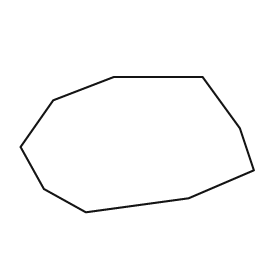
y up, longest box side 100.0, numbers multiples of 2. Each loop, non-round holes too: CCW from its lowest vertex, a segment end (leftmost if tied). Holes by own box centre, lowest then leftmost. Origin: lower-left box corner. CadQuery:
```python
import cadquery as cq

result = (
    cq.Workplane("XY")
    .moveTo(28.0, 0.0)
    .lineTo(72.0, 6.0)
    .lineTo(100.0, 18.0)
    .lineTo(94.0, 36.0)
    .lineTo(78.0, 58.0)
    .lineTo(40.0, 58.0)
    .lineTo(14.0, 48.0)
    .lineTo(0.0, 28.0)
    .lineTo(10.0, 10.0)
    .close()
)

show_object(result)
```